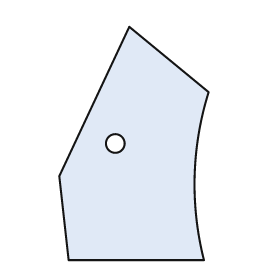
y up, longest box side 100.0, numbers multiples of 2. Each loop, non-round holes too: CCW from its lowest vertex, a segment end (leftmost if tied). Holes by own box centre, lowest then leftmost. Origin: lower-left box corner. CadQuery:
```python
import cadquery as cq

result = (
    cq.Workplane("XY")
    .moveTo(4.0, 0.0)
    .lineTo(62.0, 0.0)
    .threePointArc((58.0, 36.0), (64.0, 72.0))
    .lineTo(30.0, 100.0)
    .lineTo(0.0, 36.0)
    .close()
    .moveTo(24.0, 50.0)
    .circle(4.0)
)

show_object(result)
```